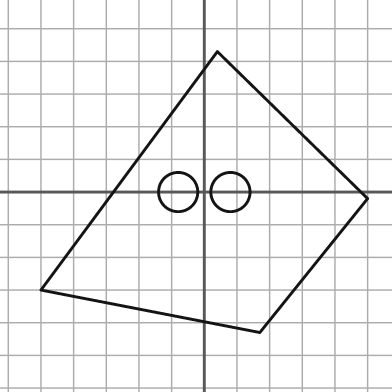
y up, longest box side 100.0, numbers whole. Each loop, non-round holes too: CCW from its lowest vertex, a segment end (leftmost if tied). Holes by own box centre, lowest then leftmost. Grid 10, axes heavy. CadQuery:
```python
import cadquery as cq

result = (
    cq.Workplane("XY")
    .moveTo(17.0, -43.0)
    .lineTo(50.0, -2.0)
    .lineTo(4.0, 43.0)
    .lineTo(-50.0, -30.0)
    .close()
    .moveTo(-8.0, 0.0)
    .circle(6.0)
    .moveTo(8.0, 0.0)
    .circle(6.0)
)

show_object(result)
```